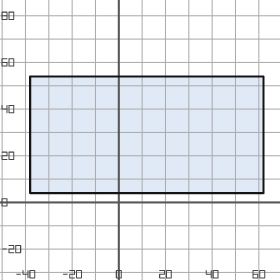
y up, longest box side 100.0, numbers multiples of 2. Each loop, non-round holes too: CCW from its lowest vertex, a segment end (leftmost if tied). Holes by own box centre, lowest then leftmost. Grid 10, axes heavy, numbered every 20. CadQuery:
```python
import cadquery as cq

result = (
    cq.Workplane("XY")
    .moveTo(-38.0, 4.0)
    .lineTo(62.0, 4.0)
    .lineTo(62.0, 54.0)
    .lineTo(-38.0, 54.0)
    .close()
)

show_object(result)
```